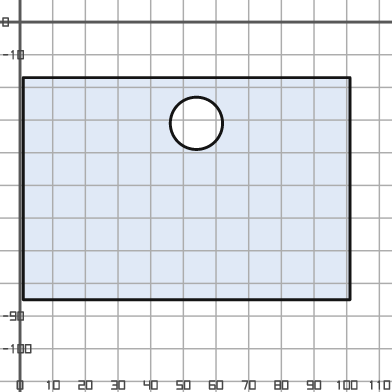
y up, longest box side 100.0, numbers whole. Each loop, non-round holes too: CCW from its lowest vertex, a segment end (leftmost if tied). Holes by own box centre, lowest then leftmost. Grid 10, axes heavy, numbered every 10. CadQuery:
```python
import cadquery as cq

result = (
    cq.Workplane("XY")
    .moveTo(1.0, -85.0)
    .lineTo(101.0, -85.0)
    .lineTo(101.0, -17.0)
    .lineTo(1.0, -17.0)
    .close()
    .moveTo(54.0, -31.0)
    .circle(8.0)
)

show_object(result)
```